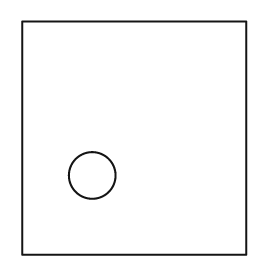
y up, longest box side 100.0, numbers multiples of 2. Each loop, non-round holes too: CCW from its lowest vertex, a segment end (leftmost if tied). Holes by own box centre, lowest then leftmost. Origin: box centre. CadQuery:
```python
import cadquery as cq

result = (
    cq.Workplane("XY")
    .moveTo(-48.0, -50.0)
    .lineTo(48.0, -50.0)
    .lineTo(48.0, 50.0)
    .lineTo(-48.0, 50.0)
    .close()
    .moveTo(-18.0, -16.0)
    .circle(10.0)
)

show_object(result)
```